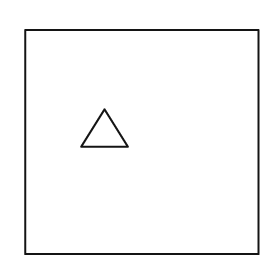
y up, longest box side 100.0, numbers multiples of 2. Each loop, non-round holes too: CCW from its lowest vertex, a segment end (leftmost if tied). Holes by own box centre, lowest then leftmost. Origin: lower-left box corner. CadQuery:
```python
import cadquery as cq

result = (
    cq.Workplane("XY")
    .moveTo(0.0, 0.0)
    .lineTo(100.0, 0.0)
    .lineTo(100.0, 96.0)
    .lineTo(0.0, 96.0)
    .close()
    .moveTo(24.0, 46.0)
    .lineTo(44.0, 46.0)
    .lineTo(34.0, 62.0)
    .close()
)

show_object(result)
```